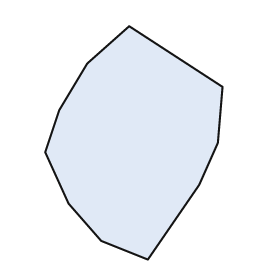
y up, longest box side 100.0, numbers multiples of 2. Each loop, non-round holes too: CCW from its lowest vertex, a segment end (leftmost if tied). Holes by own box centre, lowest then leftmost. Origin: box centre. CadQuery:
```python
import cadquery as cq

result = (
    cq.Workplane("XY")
    .moveTo(6.0, -50.0)
    .lineTo(28.0, -18.0)
    .lineTo(36.0, 0.0)
    .lineTo(38.0, 24.0)
    .lineTo(-2.0, 50.0)
    .lineTo(-20.0, 34.0)
    .lineTo(-32.0, 14.0)
    .lineTo(-38.0, -4.0)
    .lineTo(-28.0, -26.0)
    .lineTo(-14.0, -42.0)
    .close()
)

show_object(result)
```